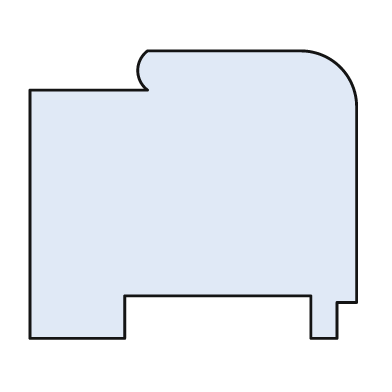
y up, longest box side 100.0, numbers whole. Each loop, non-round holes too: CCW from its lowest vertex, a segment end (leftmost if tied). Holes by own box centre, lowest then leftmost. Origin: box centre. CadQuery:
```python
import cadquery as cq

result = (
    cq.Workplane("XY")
    .moveTo(-50.0, -44.0)
    .lineTo(-21.0, -44.0)
    .lineTo(-21.0, -31.0)
    .lineTo(36.0, -31.0)
    .lineTo(36.0, -44.0)
    .lineTo(44.0, -44.0)
    .lineTo(44.0, -33.0)
    .lineTo(50.0, -33.0)
    .lineTo(50.0, 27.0)
    .threePointArc((45.0, 39.0), (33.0, 44.0))
    .lineTo(-14.0, 44.0)
    .threePointArc((-17.0, 38.0), (-14.0, 32.0))
    .lineTo(-50.0, 32.0)
    .close()
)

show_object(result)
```